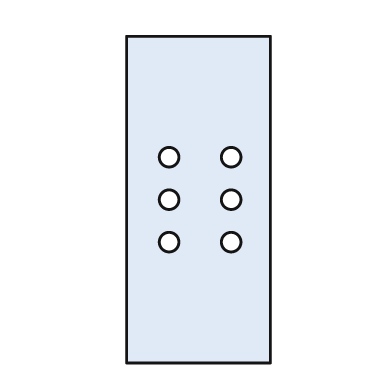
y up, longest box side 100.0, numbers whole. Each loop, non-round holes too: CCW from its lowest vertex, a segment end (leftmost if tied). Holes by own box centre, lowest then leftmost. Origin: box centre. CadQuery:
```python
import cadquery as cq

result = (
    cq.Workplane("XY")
    .moveTo(-22.0, -50.0)
    .lineTo(22.0, -50.0)
    .lineTo(22.0, 50.0)
    .lineTo(-22.0, 50.0)
    .close()
    .moveTo(-9.0, -13.0)
    .circle(3.0)
    .moveTo(10.0, -13.0)
    .circle(3.0)
    .moveTo(-9.0, 0.0)
    .circle(3.0)
    .moveTo(10.0, 0.0)
    .circle(3.0)
    .moveTo(-9.0, 13.0)
    .circle(3.0)
    .moveTo(10.0, 13.0)
    .circle(3.0)
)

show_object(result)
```